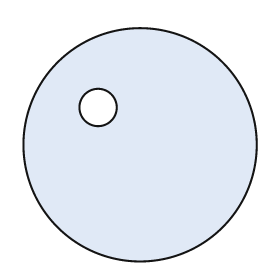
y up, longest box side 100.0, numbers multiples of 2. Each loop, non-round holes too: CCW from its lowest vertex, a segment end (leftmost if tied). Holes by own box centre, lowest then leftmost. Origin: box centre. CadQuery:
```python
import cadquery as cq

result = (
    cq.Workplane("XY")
    .moveTo(0.0, 0.0)
    .circle(50.0)
    .moveTo(-18.0, 16.0)
    .circle(8.0)
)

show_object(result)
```